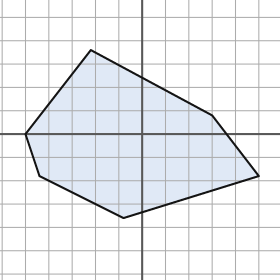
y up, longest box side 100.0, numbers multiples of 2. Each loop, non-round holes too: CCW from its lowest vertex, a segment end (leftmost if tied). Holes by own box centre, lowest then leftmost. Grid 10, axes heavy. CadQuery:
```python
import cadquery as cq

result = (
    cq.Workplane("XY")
    .moveTo(-8.0, -36.0)
    .lineTo(50.0, -18.0)
    .lineTo(30.0, 8.0)
    .lineTo(-22.0, 36.0)
    .lineTo(-50.0, 0.0)
    .lineTo(-44.0, -18.0)
    .close()
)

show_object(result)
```